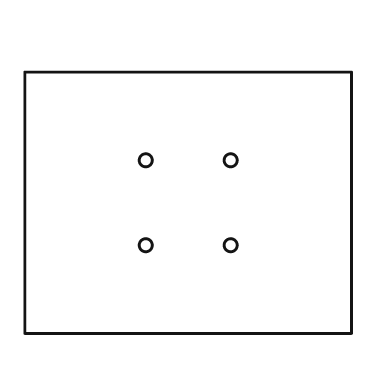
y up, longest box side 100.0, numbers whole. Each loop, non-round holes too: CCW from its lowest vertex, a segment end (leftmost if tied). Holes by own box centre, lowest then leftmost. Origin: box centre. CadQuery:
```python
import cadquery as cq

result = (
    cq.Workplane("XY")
    .moveTo(-50.0, -40.0)
    .lineTo(50.0, -40.0)
    .lineTo(50.0, 40.0)
    .lineTo(-50.0, 40.0)
    .close()
    .moveTo(-13.0, -13.0)
    .circle(2.0)
    .moveTo(13.0, -13.0)
    .circle(2.0)
    .moveTo(-13.0, 13.0)
    .circle(2.0)
    .moveTo(13.0, 13.0)
    .circle(2.0)
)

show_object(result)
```